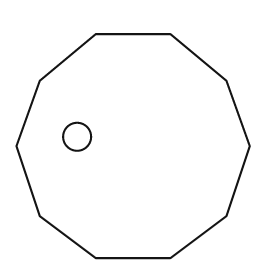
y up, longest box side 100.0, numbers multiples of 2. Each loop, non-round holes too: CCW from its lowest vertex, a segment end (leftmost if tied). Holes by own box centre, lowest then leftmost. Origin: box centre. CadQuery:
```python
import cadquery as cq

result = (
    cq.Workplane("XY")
    .moveTo(-16.0, -48.0)
    .lineTo(16.0, -48.0)
    .lineTo(40.0, -30.0)
    .lineTo(50.0, 0.0)
    .lineTo(40.0, 28.0)
    .lineTo(16.0, 48.0)
    .lineTo(-16.0, 48.0)
    .lineTo(-40.0, 28.0)
    .lineTo(-50.0, 0.0)
    .lineTo(-40.0, -30.0)
    .close()
    .moveTo(-24.0, 4.0)
    .circle(6.0)
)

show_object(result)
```